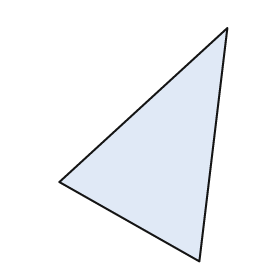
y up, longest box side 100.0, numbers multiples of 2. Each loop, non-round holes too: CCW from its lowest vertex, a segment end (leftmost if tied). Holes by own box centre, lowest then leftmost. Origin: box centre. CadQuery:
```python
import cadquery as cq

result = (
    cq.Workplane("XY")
    .moveTo(24.0, -50.0)
    .lineTo(36.0, 50.0)
    .lineTo(-36.0, -16.0)
    .close()
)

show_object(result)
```